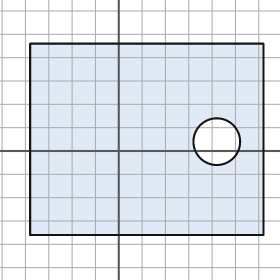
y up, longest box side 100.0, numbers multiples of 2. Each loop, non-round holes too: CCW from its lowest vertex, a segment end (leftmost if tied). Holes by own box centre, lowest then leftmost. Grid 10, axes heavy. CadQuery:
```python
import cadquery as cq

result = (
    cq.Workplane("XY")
    .moveTo(-38.0, -36.0)
    .lineTo(62.0, -36.0)
    .lineTo(62.0, 46.0)
    .lineTo(-38.0, 46.0)
    .close()
    .moveTo(42.0, 4.0)
    .circle(10.0)
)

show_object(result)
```